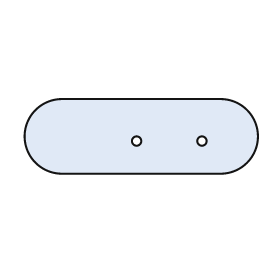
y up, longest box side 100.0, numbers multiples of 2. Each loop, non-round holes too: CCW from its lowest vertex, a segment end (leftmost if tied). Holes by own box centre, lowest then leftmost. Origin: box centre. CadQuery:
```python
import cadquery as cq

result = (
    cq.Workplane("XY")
    .moveTo(-34.0, -16.0)
    .lineTo(34.0, -16.0)
    .threePointArc((50.0, 0.0), (34.0, 16.0))
    .lineTo(-34.0, 16.0)
    .threePointArc((-50.0, 0.0), (-34.0, -16.0))
    .close()
    .moveTo(-2.0, -2.0)
    .circle(2.0)
    .moveTo(26.0, -2.0)
    .circle(2.0)
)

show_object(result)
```